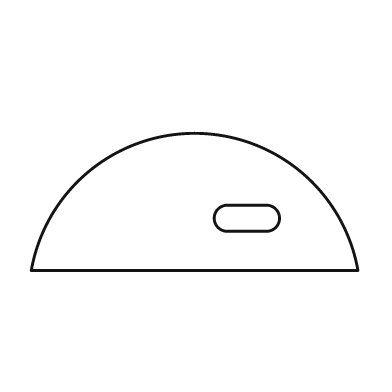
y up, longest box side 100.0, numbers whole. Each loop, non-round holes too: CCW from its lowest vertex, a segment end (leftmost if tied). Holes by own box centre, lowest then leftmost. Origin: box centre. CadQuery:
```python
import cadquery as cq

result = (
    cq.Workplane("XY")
    .moveTo(-50.0, -21.0)
    .lineTo(50.0, -21.0)
    .threePointArc((0.0, 21.0), (-50.0, -21.0))
    .close()
    .moveTo(10.0, -9.0)
    .lineTo(22.0, -9.0)
    .threePointArc((26.0, -5.0), (22.0, -1.0))
    .lineTo(10.0, -1.0)
    .threePointArc((6.0, -5.0), (10.0, -9.0))
    .close()
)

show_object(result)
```